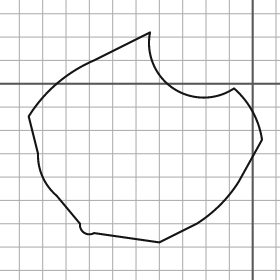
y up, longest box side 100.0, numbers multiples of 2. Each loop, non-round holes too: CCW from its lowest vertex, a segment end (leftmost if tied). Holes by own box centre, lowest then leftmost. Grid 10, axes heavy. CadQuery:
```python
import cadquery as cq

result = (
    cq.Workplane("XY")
    .moveTo(-40.0, -68.0)
    .lineTo(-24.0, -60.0)
    .threePointArc((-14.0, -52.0), (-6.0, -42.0))
    .lineTo(4.0, -24.0)
    .threePointArc((0.0, -12.0), (-8.0, -2.0))
    .threePointArc((-34.0, -2.0), (-44.0, 22.0))
    .lineTo(-68.0, 10.0)
    .threePointArc((-84.0, 0.0), (-96.0, -14.0))
    .lineTo(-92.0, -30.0)
    .threePointArc((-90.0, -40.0), (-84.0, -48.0))
    .lineTo(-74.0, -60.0)
    .threePointArc((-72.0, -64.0), (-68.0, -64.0))
    .close()
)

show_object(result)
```